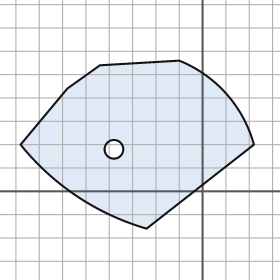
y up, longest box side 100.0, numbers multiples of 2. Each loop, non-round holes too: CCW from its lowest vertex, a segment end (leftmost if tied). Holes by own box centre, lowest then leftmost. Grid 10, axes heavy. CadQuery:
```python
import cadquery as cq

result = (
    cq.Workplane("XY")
    .moveTo(-24.0, -16.0)
    .lineTo(22.0, 20.0)
    .threePointArc((10.0, 42.0), (-10.0, 56.0))
    .lineTo(-44.0, 54.0)
    .lineTo(-58.0, 44.0)
    .lineTo(-78.0, 20.0)
    .threePointArc((-54.0, -2.0), (-24.0, -16.0))
    .close()
    .moveTo(-38.0, 18.0)
    .circle(4.0)
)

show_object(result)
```